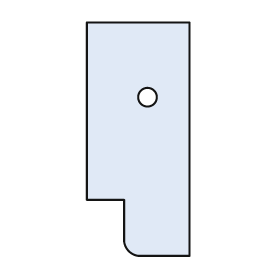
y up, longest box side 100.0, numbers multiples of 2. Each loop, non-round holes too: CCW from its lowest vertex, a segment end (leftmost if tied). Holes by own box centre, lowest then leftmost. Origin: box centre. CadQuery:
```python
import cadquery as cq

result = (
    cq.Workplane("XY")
    .moveTo(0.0, -50.0)
    .lineTo(22.0, -50.0)
    .lineTo(22.0, 50.0)
    .lineTo(-22.0, 50.0)
    .lineTo(-22.0, -26.0)
    .lineTo(-6.0, -26.0)
    .lineTo(-6.0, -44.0)
    .threePointArc((-4.0, -48.0), (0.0, -50.0))
    .close()
    .moveTo(4.0, 18.0)
    .circle(4.0)
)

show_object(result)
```